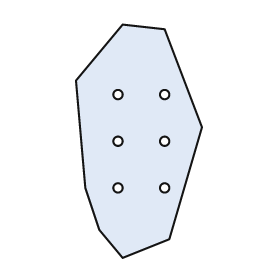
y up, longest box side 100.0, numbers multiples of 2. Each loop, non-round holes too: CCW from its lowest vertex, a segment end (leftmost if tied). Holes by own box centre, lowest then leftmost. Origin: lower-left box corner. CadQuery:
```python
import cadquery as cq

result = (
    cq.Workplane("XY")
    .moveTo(20.0, 0.0)
    .lineTo(40.0, 8.0)
    .lineTo(54.0, 56.0)
    .lineTo(38.0, 98.0)
    .lineTo(20.0, 100.0)
    .lineTo(0.0, 76.0)
    .lineTo(4.0, 30.0)
    .lineTo(10.0, 12.0)
    .close()
    .moveTo(18.0, 30.0)
    .circle(2.0)
    .moveTo(38.0, 30.0)
    .circle(2.0)
    .moveTo(18.0, 50.0)
    .circle(2.0)
    .moveTo(38.0, 50.0)
    .circle(2.0)
    .moveTo(18.0, 70.0)
    .circle(2.0)
    .moveTo(38.0, 70.0)
    .circle(2.0)
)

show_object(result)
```